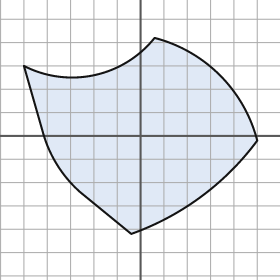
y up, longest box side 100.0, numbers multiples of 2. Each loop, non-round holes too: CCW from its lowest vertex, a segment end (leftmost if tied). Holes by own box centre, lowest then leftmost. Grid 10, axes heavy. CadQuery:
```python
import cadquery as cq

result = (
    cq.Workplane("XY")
    .moveTo(-4.0, -42.0)
    .threePointArc((26.0, -26.0), (50.0, -2.0))
    .threePointArc((34.0, 26.0), (6.0, 42.0))
    .threePointArc((-20.0, 26.0), (-50.0, 30.0))
    .lineTo(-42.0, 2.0)
    .threePointArc((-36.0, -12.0), (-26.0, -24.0))
    .close()
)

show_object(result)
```